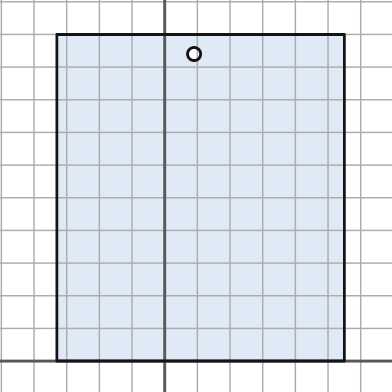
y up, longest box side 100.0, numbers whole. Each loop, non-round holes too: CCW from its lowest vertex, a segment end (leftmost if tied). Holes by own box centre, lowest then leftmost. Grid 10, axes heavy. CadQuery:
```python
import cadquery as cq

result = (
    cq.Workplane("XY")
    .moveTo(-33.0, 0.0)
    .lineTo(55.0, 0.0)
    .lineTo(55.0, 100.0)
    .lineTo(-33.0, 100.0)
    .close()
    .moveTo(9.0, 94.0)
    .circle(2.0)
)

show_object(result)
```